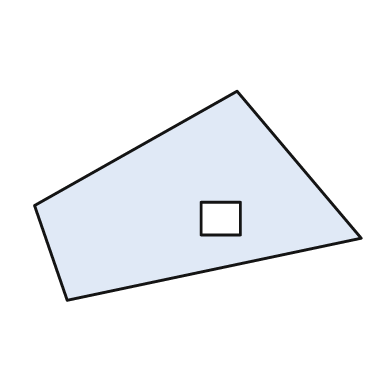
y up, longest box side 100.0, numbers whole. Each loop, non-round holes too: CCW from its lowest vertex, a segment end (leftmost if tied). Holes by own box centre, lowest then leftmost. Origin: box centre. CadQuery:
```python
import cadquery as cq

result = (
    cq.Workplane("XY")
    .moveTo(-40.0, -32.0)
    .lineTo(50.0, -13.0)
    .lineTo(12.0, 32.0)
    .lineTo(-50.0, -3.0)
    .close()
    .moveTo(1.0, -12.0)
    .lineTo(13.0, -12.0)
    .lineTo(13.0, -2.0)
    .lineTo(1.0, -2.0)
    .close()
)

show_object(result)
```